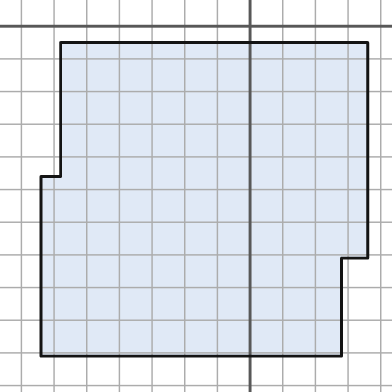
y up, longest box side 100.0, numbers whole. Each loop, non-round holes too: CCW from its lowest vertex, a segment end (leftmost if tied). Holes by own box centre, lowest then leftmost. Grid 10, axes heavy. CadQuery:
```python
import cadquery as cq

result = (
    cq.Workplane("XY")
    .moveTo(-64.0, -101.0)
    .lineTo(28.0, -101.0)
    .lineTo(28.0, -71.0)
    .lineTo(36.0, -71.0)
    .lineTo(36.0, -5.0)
    .lineTo(-58.0, -5.0)
    .lineTo(-58.0, -46.0)
    .lineTo(-64.0, -46.0)
    .close()
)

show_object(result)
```